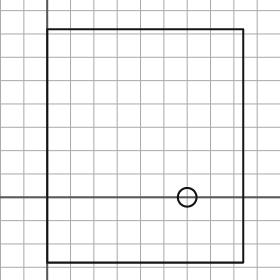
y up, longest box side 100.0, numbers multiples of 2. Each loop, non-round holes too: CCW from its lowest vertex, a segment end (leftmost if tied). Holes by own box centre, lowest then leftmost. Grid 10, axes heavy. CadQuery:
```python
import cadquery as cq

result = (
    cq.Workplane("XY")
    .moveTo(0.0, -28.0)
    .lineTo(84.0, -28.0)
    .lineTo(84.0, 72.0)
    .lineTo(0.0, 72.0)
    .close()
    .moveTo(60.0, 0.0)
    .circle(4.0)
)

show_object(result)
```